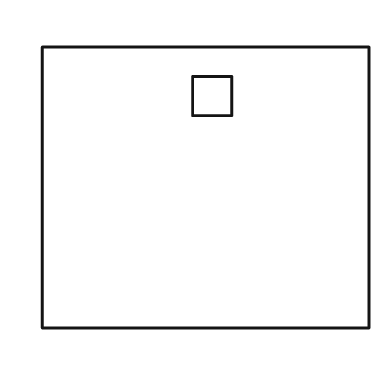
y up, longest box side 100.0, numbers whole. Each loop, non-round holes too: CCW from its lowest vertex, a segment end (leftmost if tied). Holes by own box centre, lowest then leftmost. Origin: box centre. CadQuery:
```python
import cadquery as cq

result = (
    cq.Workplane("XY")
    .moveTo(-50.0, -43.0)
    .lineTo(50.0, -43.0)
    .lineTo(50.0, 43.0)
    .lineTo(-50.0, 43.0)
    .close()
    .moveTo(-4.0, 22.0)
    .lineTo(8.0, 22.0)
    .lineTo(8.0, 34.0)
    .lineTo(-4.0, 34.0)
    .close()
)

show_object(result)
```